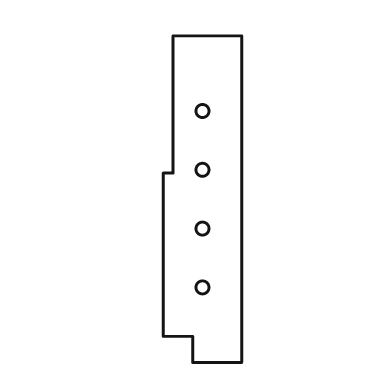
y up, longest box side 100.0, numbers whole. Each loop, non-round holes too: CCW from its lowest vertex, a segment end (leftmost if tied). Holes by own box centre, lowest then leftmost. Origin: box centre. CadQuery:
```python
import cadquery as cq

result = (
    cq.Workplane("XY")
    .moveTo(-3.0, -50.0)
    .lineTo(12.0, -50.0)
    .lineTo(12.0, 50.0)
    .lineTo(-9.0, 50.0)
    .lineTo(-9.0, 8.0)
    .lineTo(-12.0, 8.0)
    .lineTo(-12.0, -42.0)
    .lineTo(-3.0, -42.0)
    .close()
    .moveTo(0.0, -27.0)
    .circle(2.0)
    .moveTo(0.0, -9.0)
    .circle(2.0)
    .moveTo(0.0, 9.0)
    .circle(2.0)
    .moveTo(0.0, 27.0)
    .circle(2.0)
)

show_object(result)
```